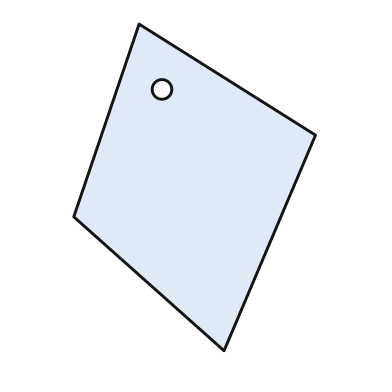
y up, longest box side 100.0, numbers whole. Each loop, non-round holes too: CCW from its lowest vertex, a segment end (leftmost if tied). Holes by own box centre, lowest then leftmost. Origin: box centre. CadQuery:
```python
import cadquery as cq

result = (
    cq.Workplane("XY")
    .moveTo(9.0, -50.0)
    .lineTo(37.0, 16.0)
    .lineTo(-17.0, 50.0)
    .lineTo(-37.0, -9.0)
    .close()
    .moveTo(-10.0, 30.0)
    .circle(3.0)
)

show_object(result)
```